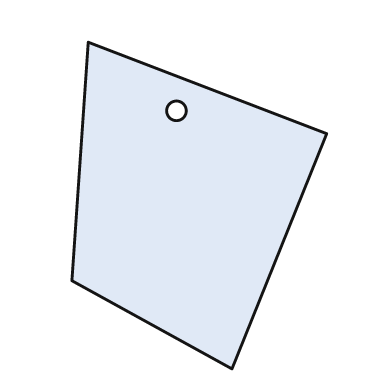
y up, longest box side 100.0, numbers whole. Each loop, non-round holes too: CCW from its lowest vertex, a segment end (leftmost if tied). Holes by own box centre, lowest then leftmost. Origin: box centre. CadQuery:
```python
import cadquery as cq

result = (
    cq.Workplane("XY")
    .moveTo(10.0, -50.0)
    .lineTo(39.0, 22.0)
    .lineTo(-34.0, 50.0)
    .lineTo(-39.0, -23.0)
    .close()
    .moveTo(-7.0, 29.0)
    .circle(3.0)
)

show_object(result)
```